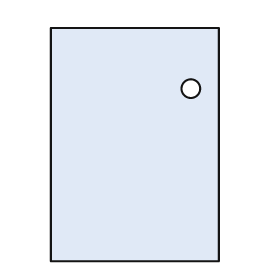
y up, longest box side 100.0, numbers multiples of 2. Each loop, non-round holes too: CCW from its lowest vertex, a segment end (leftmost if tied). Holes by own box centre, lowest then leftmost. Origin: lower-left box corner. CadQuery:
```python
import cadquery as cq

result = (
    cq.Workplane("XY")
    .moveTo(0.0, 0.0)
    .lineTo(72.0, 0.0)
    .lineTo(72.0, 100.0)
    .lineTo(0.0, 100.0)
    .close()
    .moveTo(60.0, 74.0)
    .circle(4.0)
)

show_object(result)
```